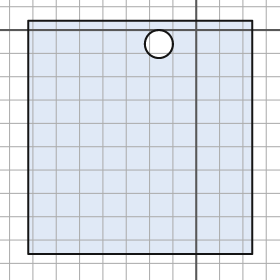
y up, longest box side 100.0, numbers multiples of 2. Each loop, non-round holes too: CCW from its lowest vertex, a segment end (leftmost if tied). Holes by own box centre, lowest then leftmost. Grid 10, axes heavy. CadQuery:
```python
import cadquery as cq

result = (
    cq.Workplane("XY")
    .moveTo(-72.0, -96.0)
    .lineTo(24.0, -96.0)
    .lineTo(24.0, 4.0)
    .lineTo(-72.0, 4.0)
    .close()
    .moveTo(-16.0, -6.0)
    .circle(6.0)
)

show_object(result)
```